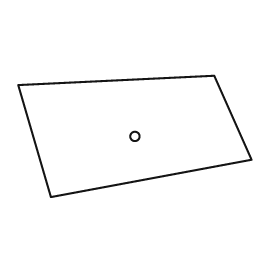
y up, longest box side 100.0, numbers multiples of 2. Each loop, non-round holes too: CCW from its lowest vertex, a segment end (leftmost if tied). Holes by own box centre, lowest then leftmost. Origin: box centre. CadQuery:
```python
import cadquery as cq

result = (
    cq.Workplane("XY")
    .moveTo(-36.0, -26.0)
    .lineTo(50.0, -10.0)
    .lineTo(34.0, 26.0)
    .lineTo(-50.0, 22.0)
    .close()
    .moveTo(0.0, 0.0)
    .circle(2.0)
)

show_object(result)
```